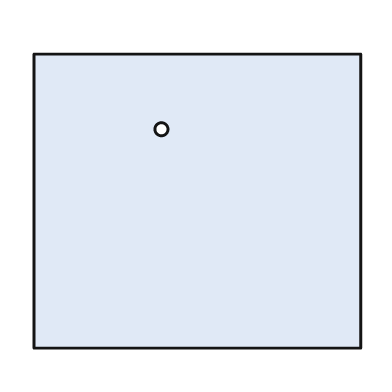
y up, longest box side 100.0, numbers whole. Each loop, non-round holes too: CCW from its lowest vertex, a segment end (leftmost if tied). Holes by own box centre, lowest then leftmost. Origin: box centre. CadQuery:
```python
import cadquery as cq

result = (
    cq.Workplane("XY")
    .moveTo(-50.0, -45.0)
    .lineTo(50.0, -45.0)
    .lineTo(50.0, 45.0)
    .lineTo(-50.0, 45.0)
    .close()
    .moveTo(-11.0, 22.0)
    .circle(2.0)
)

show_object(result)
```